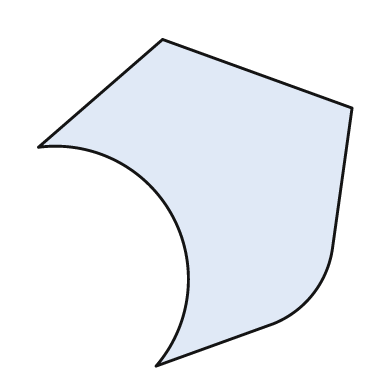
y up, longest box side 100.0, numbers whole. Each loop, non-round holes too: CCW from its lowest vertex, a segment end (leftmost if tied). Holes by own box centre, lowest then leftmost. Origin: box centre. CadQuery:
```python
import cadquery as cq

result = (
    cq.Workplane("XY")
    .moveTo(-12.0, -50.0)
    .lineTo(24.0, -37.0)
    .threePointArc((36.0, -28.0), (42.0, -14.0))
    .lineTo(48.0, 29.0)
    .lineTo(-10.0, 50.0)
    .lineTo(-48.0, 17.0)
    .threePointArc((-7.0, -4.0), (-12.0, -50.0))
    .close()
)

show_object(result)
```